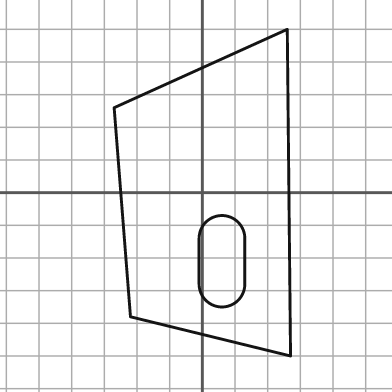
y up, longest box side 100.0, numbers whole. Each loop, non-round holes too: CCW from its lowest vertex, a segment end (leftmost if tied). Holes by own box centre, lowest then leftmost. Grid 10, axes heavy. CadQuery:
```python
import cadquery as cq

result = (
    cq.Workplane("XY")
    .moveTo(27.0, -50.0)
    .lineTo(26.0, 50.0)
    .lineTo(-27.0, 26.0)
    .lineTo(-22.0, -38.0)
    .close()
    .moveTo(-1.0, -28.0)
    .threePointArc((6.0, -35.0), (13.0, -28.0))
    .lineTo(13.0, -14.0)
    .threePointArc((6.0, -7.0), (-1.0, -14.0))
    .close()
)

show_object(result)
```